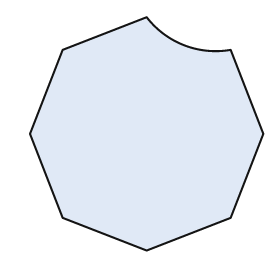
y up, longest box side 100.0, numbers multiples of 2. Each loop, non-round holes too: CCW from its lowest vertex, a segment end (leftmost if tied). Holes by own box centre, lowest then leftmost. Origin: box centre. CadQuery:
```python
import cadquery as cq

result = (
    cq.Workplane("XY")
    .moveTo(0.0, -50.0)
    .lineTo(36.0, -36.0)
    .lineTo(50.0, 0.0)
    .lineTo(36.0, 36.0)
    .threePointArc((16.0, 38.0), (0.0, 50.0))
    .lineTo(-36.0, 36.0)
    .lineTo(-50.0, 0.0)
    .lineTo(-36.0, -36.0)
    .close()
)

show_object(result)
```